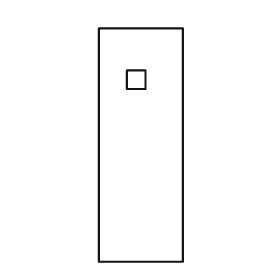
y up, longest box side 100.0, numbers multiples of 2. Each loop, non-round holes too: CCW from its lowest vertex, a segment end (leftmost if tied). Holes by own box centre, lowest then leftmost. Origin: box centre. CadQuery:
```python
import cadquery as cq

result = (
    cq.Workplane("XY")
    .moveTo(-18.0, -50.0)
    .lineTo(18.0, -50.0)
    .lineTo(18.0, 50.0)
    .lineTo(-18.0, 50.0)
    .close()
    .moveTo(-6.0, 24.0)
    .lineTo(2.0, 24.0)
    .lineTo(2.0, 32.0)
    .lineTo(-6.0, 32.0)
    .close()
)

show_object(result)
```